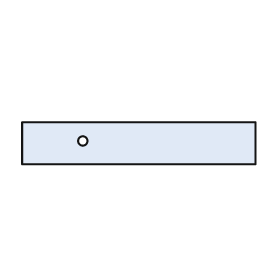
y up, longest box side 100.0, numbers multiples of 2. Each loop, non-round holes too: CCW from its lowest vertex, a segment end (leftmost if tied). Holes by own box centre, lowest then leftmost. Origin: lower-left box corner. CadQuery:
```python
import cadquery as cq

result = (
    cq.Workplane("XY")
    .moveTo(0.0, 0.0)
    .lineTo(100.0, 0.0)
    .lineTo(100.0, 18.0)
    .lineTo(0.0, 18.0)
    .close()
    .moveTo(26.0, 10.0)
    .circle(2.0)
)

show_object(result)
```